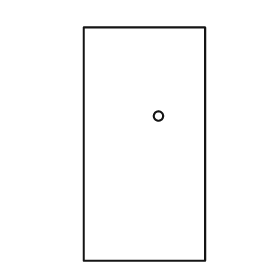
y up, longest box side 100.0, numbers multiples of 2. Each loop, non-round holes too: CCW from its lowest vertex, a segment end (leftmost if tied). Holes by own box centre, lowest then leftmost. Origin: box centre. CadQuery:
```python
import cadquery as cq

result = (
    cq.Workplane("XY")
    .moveTo(-26.0, -50.0)
    .lineTo(26.0, -50.0)
    .lineTo(26.0, 50.0)
    .lineTo(-26.0, 50.0)
    .close()
    .moveTo(6.0, 12.0)
    .circle(2.0)
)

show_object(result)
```